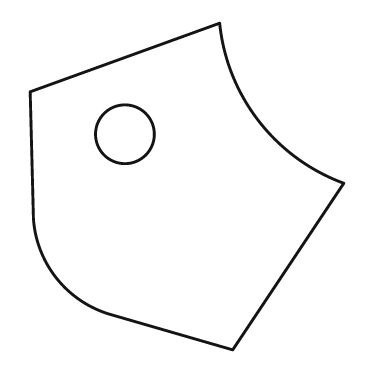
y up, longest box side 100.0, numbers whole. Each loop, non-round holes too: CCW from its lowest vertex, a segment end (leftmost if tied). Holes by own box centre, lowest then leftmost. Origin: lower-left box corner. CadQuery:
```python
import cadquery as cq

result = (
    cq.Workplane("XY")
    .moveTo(62.0, 0.0)
    .lineTo(96.0, 51.0)
    .threePointArc((70.0, 70.0), (58.0, 100.0))
    .lineTo(0.0, 79.0)
    .lineTo(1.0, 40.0)
    .threePointArc((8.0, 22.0), (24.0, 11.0))
    .close()
    .moveTo(29.0, 66.0)
    .circle(9.0)
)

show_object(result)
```